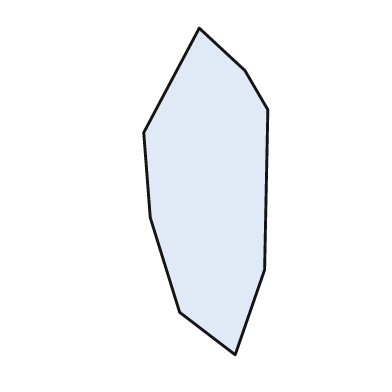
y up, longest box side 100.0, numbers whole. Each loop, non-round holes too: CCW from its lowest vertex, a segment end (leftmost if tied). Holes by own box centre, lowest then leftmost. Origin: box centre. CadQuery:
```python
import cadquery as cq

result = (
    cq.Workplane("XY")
    .moveTo(9.0, -50.0)
    .lineTo(18.0, -24.0)
    .lineTo(19.0, 25.0)
    .lineTo(12.0, 37.0)
    .lineTo(-2.0, 50.0)
    .lineTo(-19.0, 18.0)
    .lineTo(-17.0, -8.0)
    .lineTo(-8.0, -37.0)
    .close()
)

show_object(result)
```